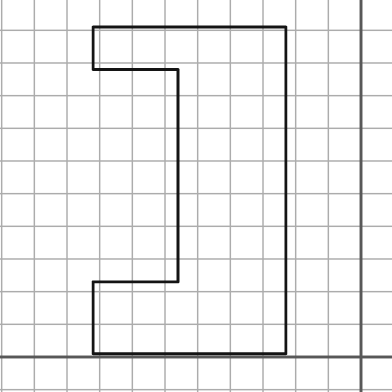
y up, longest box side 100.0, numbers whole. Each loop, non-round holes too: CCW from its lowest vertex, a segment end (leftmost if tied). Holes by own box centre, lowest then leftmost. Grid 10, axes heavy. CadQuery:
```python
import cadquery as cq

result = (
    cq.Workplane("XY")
    .moveTo(-82.0, 1.0)
    .lineTo(-23.0, 1.0)
    .lineTo(-23.0, 101.0)
    .lineTo(-82.0, 101.0)
    .lineTo(-82.0, 88.0)
    .lineTo(-56.0, 88.0)
    .lineTo(-56.0, 23.0)
    .lineTo(-82.0, 23.0)
    .close()
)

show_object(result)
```